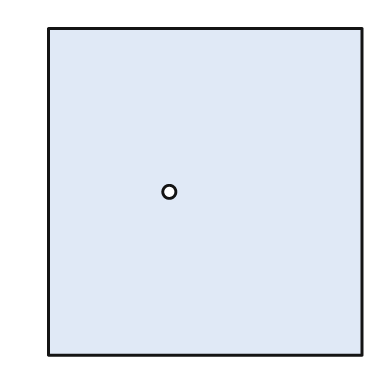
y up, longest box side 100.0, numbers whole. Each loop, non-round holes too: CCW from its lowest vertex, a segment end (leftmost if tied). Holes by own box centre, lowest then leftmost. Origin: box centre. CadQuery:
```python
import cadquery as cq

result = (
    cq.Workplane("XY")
    .moveTo(-48.0, -50.0)
    .lineTo(48.0, -50.0)
    .lineTo(48.0, 50.0)
    .lineTo(-48.0, 50.0)
    .close()
    .moveTo(-11.0, 0.0)
    .circle(2.0)
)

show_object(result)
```